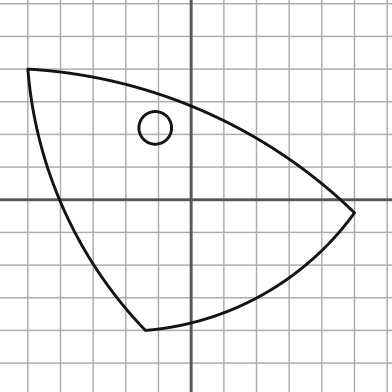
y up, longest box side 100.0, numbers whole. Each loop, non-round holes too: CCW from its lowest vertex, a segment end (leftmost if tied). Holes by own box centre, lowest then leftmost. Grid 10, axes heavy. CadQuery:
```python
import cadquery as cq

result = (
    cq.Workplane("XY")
    .moveTo(-14.0, -40.0)
    .threePointArc((22.0, -29.0), (50.0, -4.0))
    .threePointArc((4.0, 27.0), (-50.0, 40.0))
    .threePointArc((-39.0, -3.0), (-14.0, -40.0))
    .close()
    .moveTo(-11.0, 22.0)
    .circle(5.0)
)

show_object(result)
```